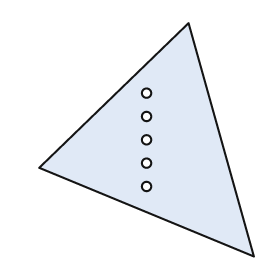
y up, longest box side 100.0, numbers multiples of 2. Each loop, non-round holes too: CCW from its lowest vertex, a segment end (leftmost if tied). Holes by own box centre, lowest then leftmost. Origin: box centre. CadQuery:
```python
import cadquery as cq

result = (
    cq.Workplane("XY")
    .moveTo(46.0, -50.0)
    .lineTo(18.0, 50.0)
    .lineTo(-46.0, -12.0)
    .close()
    .moveTo(0.0, -20.0)
    .circle(2.0)
    .moveTo(0.0, -10.0)
    .circle(2.0)
    .moveTo(0.0, 0.0)
    .circle(2.0)
    .moveTo(0.0, 10.0)
    .circle(2.0)
    .moveTo(0.0, 20.0)
    .circle(2.0)
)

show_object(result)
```